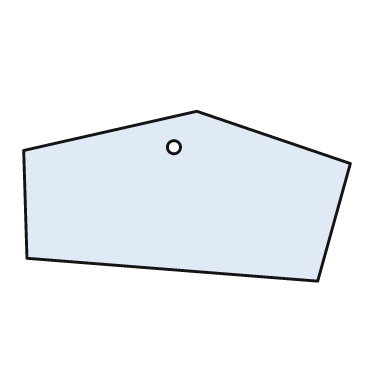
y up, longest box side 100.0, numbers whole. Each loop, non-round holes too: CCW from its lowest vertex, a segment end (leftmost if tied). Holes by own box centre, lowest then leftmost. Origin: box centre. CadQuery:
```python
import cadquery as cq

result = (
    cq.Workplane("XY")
    .moveTo(40.0, -26.0)
    .lineTo(50.0, 10.0)
    .lineTo(3.0, 26.0)
    .lineTo(-50.0, 14.0)
    .lineTo(-49.0, -19.0)
    .close()
    .moveTo(-4.0, 15.0)
    .circle(2.0)
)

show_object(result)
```